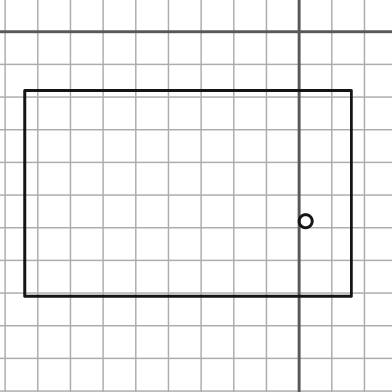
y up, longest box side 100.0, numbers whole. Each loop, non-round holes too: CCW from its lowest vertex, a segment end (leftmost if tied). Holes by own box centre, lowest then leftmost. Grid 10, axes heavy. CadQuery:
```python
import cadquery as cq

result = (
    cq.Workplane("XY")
    .moveTo(-84.0, -81.0)
    .lineTo(16.0, -81.0)
    .lineTo(16.0, -18.0)
    .lineTo(-84.0, -18.0)
    .close()
    .moveTo(2.0, -58.0)
    .circle(2.0)
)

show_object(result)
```